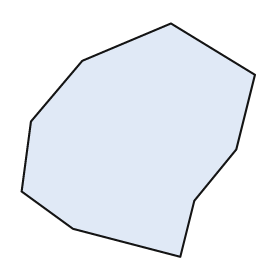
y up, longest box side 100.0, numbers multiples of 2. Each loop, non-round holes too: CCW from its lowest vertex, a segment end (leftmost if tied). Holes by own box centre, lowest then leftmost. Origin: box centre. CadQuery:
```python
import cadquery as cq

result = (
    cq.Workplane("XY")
    .moveTo(18.0, -50.0)
    .lineTo(24.0, -26.0)
    .lineTo(42.0, -4.0)
    .lineTo(50.0, 28.0)
    .lineTo(14.0, 50.0)
    .lineTo(-24.0, 34.0)
    .lineTo(-46.0, 8.0)
    .lineTo(-50.0, -22.0)
    .lineTo(-28.0, -38.0)
    .close()
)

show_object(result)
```